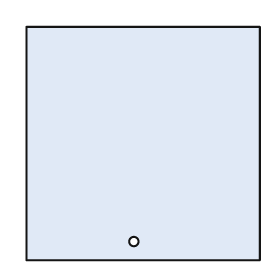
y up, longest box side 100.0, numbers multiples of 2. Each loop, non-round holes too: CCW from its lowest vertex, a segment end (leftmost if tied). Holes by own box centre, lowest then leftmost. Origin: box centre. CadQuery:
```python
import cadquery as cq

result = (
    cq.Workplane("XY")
    .moveTo(-50.0, -50.0)
    .lineTo(50.0, -50.0)
    .lineTo(50.0, 50.0)
    .lineTo(-50.0, 50.0)
    .close()
    .moveTo(-4.0, -42.0)
    .circle(2.0)
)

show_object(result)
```